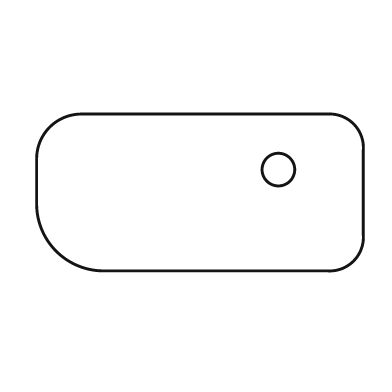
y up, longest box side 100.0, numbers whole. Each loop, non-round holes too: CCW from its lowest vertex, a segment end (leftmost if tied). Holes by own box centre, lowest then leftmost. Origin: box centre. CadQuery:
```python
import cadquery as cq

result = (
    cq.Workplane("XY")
    .moveTo(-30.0, -24.0)
    .lineTo(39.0, -24.0)
    .threePointArc((47.0, -21.0), (50.0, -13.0))
    .lineTo(50.0, 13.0)
    .threePointArc((47.0, 21.0), (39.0, 24.0))
    .lineTo(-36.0, 24.0)
    .threePointArc((-46.0, 20.0), (-50.0, 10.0))
    .lineTo(-50.0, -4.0)
    .threePointArc((-44.0, -18.0), (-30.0, -24.0))
    .close()
    .moveTo(24.0, 7.0)
    .circle(5.0)
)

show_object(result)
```